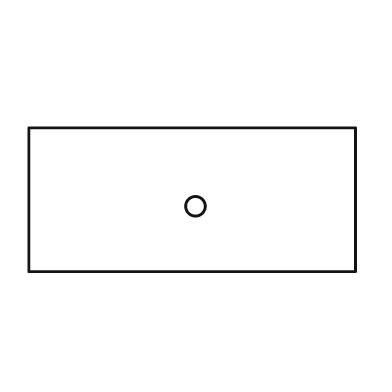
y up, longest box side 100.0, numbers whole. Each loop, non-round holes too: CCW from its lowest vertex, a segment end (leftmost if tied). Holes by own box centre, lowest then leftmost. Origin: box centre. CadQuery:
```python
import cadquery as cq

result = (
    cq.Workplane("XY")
    .moveTo(-50.0, -22.0)
    .lineTo(50.0, -22.0)
    .lineTo(50.0, 22.0)
    .lineTo(-50.0, 22.0)
    .close()
    .moveTo(1.0, -2.0)
    .circle(3.0)
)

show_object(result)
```